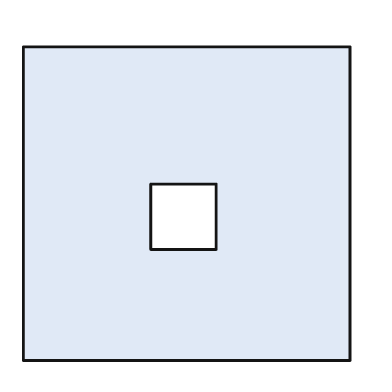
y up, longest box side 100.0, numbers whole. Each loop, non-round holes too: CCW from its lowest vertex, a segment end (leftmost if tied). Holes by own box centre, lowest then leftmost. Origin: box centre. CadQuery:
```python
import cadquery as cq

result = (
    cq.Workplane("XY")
    .moveTo(-50.0, -48.0)
    .lineTo(50.0, -48.0)
    .lineTo(50.0, 48.0)
    .lineTo(-50.0, 48.0)
    .close()
    .moveTo(-11.0, -14.0)
    .lineTo(9.0, -14.0)
    .lineTo(9.0, 6.0)
    .lineTo(-11.0, 6.0)
    .close()
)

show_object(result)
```